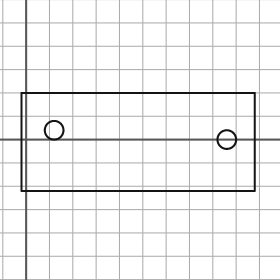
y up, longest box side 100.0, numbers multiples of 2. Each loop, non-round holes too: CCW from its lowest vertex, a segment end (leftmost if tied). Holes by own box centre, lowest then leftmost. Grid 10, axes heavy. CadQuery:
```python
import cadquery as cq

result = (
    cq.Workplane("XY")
    .moveTo(-2.0, -22.0)
    .lineTo(98.0, -22.0)
    .lineTo(98.0, 20.0)
    .lineTo(-2.0, 20.0)
    .close()
    .moveTo(86.0, 0.0)
    .circle(4.0)
    .moveTo(12.0, 4.0)
    .circle(4.0)
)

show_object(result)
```